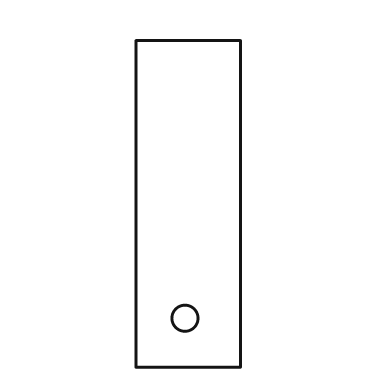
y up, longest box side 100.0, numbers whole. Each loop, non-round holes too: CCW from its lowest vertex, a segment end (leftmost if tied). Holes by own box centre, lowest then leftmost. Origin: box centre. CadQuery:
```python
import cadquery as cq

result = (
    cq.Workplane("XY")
    .moveTo(-16.0, -50.0)
    .lineTo(16.0, -50.0)
    .lineTo(16.0, 50.0)
    .lineTo(-16.0, 50.0)
    .close()
    .moveTo(-1.0, -35.0)
    .circle(4.0)
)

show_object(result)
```